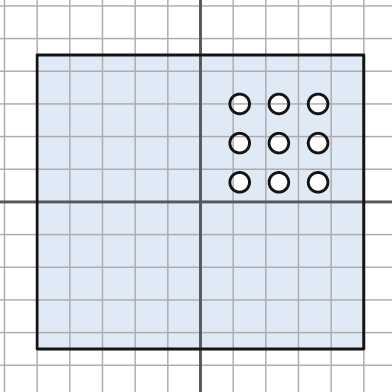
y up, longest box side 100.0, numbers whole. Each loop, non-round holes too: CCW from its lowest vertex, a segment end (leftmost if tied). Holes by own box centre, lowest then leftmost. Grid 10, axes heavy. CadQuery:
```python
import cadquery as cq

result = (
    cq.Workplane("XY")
    .moveTo(-50.0, -45.0)
    .lineTo(50.0, -45.0)
    .lineTo(50.0, 45.0)
    .lineTo(-50.0, 45.0)
    .close()
    .moveTo(12.0, 6.0)
    .circle(3.0)
    .moveTo(24.0, 6.0)
    .circle(3.0)
    .moveTo(36.0, 6.0)
    .circle(3.0)
    .moveTo(12.0, 18.0)
    .circle(3.0)
    .moveTo(24.0, 18.0)
    .circle(3.0)
    .moveTo(36.0, 18.0)
    .circle(3.0)
    .moveTo(12.0, 30.0)
    .circle(3.0)
    .moveTo(24.0, 30.0)
    .circle(3.0)
    .moveTo(36.0, 30.0)
    .circle(3.0)
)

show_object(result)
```